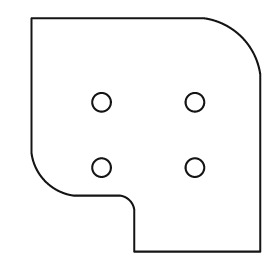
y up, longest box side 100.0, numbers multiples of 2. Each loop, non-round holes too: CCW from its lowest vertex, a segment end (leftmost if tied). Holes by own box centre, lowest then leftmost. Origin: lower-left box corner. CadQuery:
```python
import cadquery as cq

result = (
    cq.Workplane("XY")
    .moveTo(44.0, 0.0)
    .lineTo(98.0, 0.0)
    .lineTo(98.0, 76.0)
    .threePointArc((90.0, 92.0), (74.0, 100.0))
    .lineTo(0.0, 100.0)
    .lineTo(0.0, 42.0)
    .threePointArc((6.0, 30.0), (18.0, 24.0))
    .lineTo(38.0, 24.0)
    .threePointArc((42.0, 22.0), (44.0, 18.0))
    .close()
    .moveTo(30.0, 36.0)
    .circle(4.0)
    .moveTo(70.0, 36.0)
    .circle(4.0)
    .moveTo(30.0, 64.0)
    .circle(4.0)
    .moveTo(70.0, 64.0)
    .circle(4.0)
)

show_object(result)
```